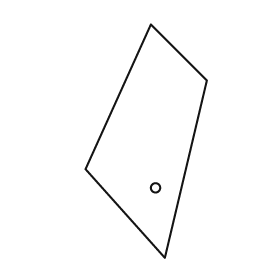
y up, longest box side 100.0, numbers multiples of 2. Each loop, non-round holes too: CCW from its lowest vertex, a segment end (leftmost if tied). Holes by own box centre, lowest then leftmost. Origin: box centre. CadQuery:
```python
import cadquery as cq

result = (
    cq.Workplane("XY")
    .moveTo(8.0, -50.0)
    .lineTo(26.0, 26.0)
    .lineTo(2.0, 50.0)
    .lineTo(-26.0, -12.0)
    .close()
    .moveTo(4.0, -20.0)
    .circle(2.0)
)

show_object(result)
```